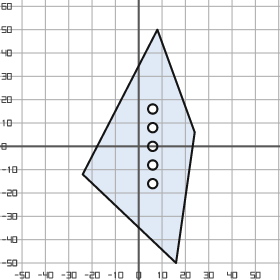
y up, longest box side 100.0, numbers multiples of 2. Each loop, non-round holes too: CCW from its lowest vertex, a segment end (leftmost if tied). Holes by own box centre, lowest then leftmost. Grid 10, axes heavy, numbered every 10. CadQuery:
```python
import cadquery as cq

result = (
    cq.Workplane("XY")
    .moveTo(16.0, -50.0)
    .lineTo(24.0, 6.0)
    .lineTo(8.0, 50.0)
    .lineTo(-24.0, -12.0)
    .close()
    .moveTo(6.0, -16.0)
    .circle(2.0)
    .moveTo(6.0, -8.0)
    .circle(2.0)
    .moveTo(6.0, 0.0)
    .circle(2.0)
    .moveTo(6.0, 8.0)
    .circle(2.0)
    .moveTo(6.0, 16.0)
    .circle(2.0)
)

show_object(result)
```